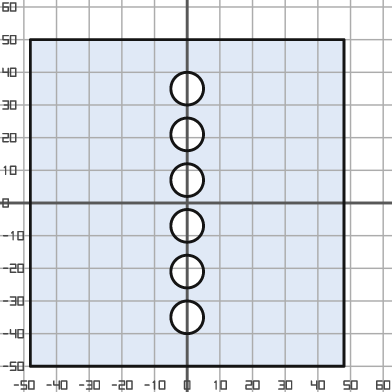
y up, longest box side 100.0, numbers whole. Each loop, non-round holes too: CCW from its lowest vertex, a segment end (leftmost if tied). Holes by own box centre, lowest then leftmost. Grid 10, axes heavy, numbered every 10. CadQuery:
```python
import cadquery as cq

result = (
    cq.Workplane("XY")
    .moveTo(-48.0, -50.0)
    .lineTo(48.0, -50.0)
    .lineTo(48.0, 50.0)
    .lineTo(-48.0, 50.0)
    .close()
    .moveTo(0.0, -35.0)
    .circle(5.0)
    .moveTo(0.0, -21.0)
    .circle(5.0)
    .moveTo(0.0, -7.0)
    .circle(5.0)
    .moveTo(0.0, 7.0)
    .circle(5.0)
    .moveTo(0.0, 21.0)
    .circle(5.0)
    .moveTo(0.0, 35.0)
    .circle(5.0)
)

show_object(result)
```